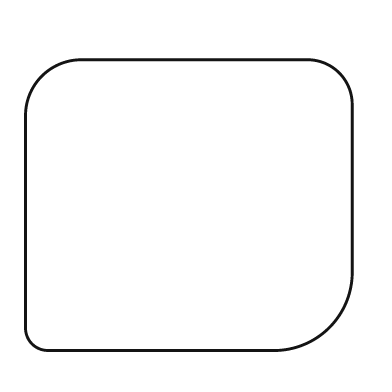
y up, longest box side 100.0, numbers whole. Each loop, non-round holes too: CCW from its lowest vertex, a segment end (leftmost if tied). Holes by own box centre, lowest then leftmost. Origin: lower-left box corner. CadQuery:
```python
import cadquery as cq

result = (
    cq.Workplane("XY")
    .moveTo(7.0, 0.0)
    .lineTo(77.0, 0.0)
    .threePointArc((93.0, 7.0), (100.0, 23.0))
    .lineTo(100.0, 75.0)
    .threePointArc((96.0, 85.0), (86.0, 89.0))
    .lineTo(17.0, 89.0)
    .threePointArc((5.0, 84.0), (0.0, 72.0))
    .lineTo(0.0, 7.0)
    .threePointArc((2.0, 2.0), (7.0, 0.0))
    .close()
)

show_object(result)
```